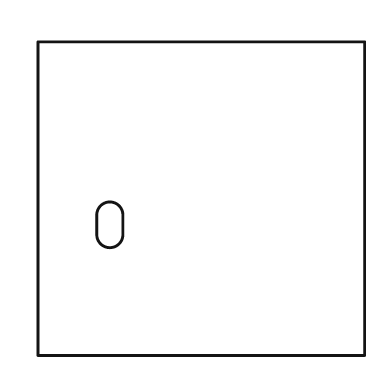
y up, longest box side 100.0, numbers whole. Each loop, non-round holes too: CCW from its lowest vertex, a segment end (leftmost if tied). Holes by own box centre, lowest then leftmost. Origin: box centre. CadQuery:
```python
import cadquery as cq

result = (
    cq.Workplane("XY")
    .moveTo(-50.0, -48.0)
    .lineTo(50.0, -48.0)
    .lineTo(50.0, 48.0)
    .lineTo(-50.0, 48.0)
    .close()
    .moveTo(-32.0, -11.0)
    .threePointArc((-28.0, -15.0), (-24.0, -11.0))
    .lineTo(-24.0, -5.0)
    .threePointArc((-28.0, -1.0), (-32.0, -5.0))
    .close()
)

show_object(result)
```